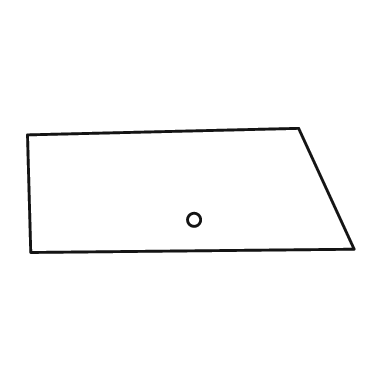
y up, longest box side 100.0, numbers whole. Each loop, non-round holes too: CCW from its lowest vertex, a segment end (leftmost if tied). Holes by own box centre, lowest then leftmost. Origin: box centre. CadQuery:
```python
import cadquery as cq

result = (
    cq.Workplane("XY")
    .moveTo(-49.0, -19.0)
    .lineTo(50.0, -18.0)
    .lineTo(33.0, 19.0)
    .lineTo(-50.0, 17.0)
    .close()
    .moveTo(1.0, -9.0)
    .circle(2.0)
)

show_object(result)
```